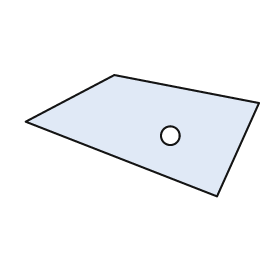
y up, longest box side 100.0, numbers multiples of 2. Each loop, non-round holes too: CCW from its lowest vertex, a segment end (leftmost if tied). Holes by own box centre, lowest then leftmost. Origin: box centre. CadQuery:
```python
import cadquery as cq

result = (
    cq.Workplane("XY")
    .moveTo(32.0, -26.0)
    .lineTo(50.0, 14.0)
    .lineTo(-12.0, 26.0)
    .lineTo(-50.0, 6.0)
    .close()
    .moveTo(12.0, 0.0)
    .circle(4.0)
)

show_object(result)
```